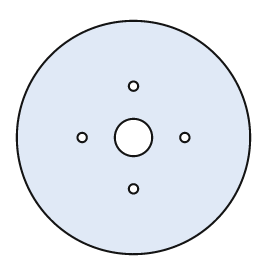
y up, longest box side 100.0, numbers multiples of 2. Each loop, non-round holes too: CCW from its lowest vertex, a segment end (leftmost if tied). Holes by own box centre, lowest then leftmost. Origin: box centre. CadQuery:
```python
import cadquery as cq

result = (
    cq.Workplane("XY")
    .moveTo(0.0, 0.0)
    .circle(50.0)
    .moveTo(0.0, -22.0)
    .circle(2.0)
    .moveTo(-22.0, 0.0)
    .circle(2.0)
    .moveTo(0.0, 0.0)
    .circle(8.0)
    .moveTo(22.0, 0.0)
    .circle(2.0)
    .moveTo(0.0, 22.0)
    .circle(2.0)
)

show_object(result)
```